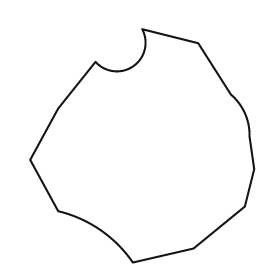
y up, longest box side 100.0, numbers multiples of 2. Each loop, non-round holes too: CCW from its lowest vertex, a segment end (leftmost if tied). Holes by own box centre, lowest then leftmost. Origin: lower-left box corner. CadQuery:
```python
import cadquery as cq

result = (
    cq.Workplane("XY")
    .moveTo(44.0, 0.0)
    .lineTo(70.0, 6.0)
    .lineTo(92.0, 24.0)
    .lineTo(96.0, 40.0)
    .lineTo(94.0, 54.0)
    .threePointArc((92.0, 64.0), (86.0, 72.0))
    .lineTo(72.0, 94.0)
    .lineTo(48.0, 100.0)
    .threePointArc((44.0, 84.0), (28.0, 86.0))
    .lineTo(12.0, 66.0)
    .lineTo(0.0, 44.0)
    .lineTo(12.0, 22.0)
    .threePointArc((30.0, 14.0), (44.0, 0.0))
    .close()
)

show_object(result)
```